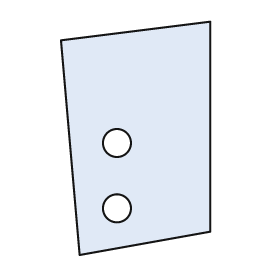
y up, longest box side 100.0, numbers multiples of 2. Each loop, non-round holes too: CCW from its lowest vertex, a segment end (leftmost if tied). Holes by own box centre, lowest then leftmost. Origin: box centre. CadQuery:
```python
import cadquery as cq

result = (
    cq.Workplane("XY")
    .moveTo(-24.0, -50.0)
    .lineTo(32.0, -40.0)
    .lineTo(32.0, 50.0)
    .lineTo(-32.0, 42.0)
    .close()
    .moveTo(-8.0, -30.0)
    .circle(6.0)
    .moveTo(-8.0, -2.0)
    .circle(6.0)
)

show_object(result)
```